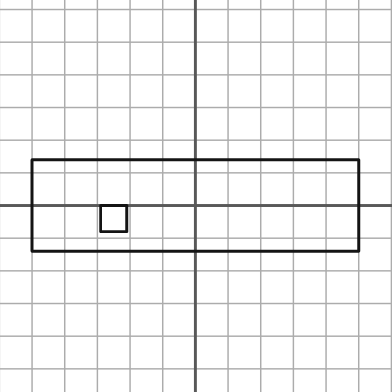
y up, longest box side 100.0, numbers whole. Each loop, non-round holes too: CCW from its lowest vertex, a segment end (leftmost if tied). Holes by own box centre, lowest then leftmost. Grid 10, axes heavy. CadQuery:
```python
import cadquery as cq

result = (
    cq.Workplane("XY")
    .moveTo(-50.0, -14.0)
    .lineTo(50.0, -14.0)
    .lineTo(50.0, 14.0)
    .lineTo(-50.0, 14.0)
    .close()
    .moveTo(-29.0, -8.0)
    .lineTo(-21.0, -8.0)
    .lineTo(-21.0, 0.0)
    .lineTo(-29.0, 0.0)
    .close()
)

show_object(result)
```